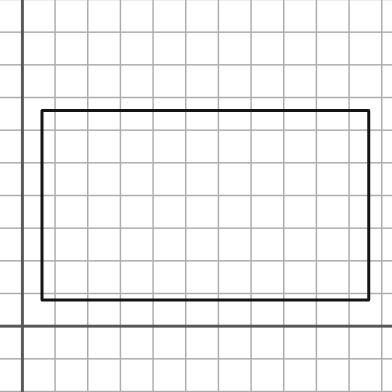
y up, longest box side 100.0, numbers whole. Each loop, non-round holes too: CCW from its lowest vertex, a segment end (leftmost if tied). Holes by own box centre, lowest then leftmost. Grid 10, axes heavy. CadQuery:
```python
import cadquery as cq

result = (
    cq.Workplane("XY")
    .moveTo(6.0, 8.0)
    .lineTo(106.0, 8.0)
    .lineTo(106.0, 66.0)
    .lineTo(6.0, 66.0)
    .close()
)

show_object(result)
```